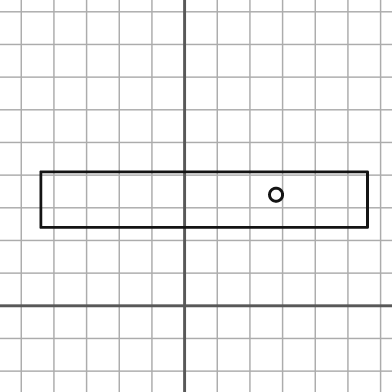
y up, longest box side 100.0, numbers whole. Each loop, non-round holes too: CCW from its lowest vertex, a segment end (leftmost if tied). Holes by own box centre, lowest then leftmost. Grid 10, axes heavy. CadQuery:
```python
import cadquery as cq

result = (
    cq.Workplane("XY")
    .moveTo(-44.0, 24.0)
    .lineTo(56.0, 24.0)
    .lineTo(56.0, 41.0)
    .lineTo(-44.0, 41.0)
    .close()
    .moveTo(28.0, 34.0)
    .circle(2.0)
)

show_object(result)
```